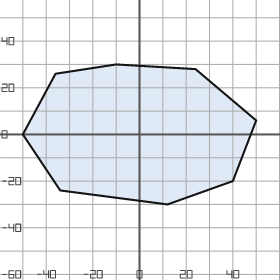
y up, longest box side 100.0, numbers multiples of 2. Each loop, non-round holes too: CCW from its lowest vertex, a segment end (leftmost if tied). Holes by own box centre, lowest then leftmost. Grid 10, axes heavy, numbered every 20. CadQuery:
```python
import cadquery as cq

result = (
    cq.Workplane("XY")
    .moveTo(12.0, -30.0)
    .lineTo(40.0, -20.0)
    .lineTo(50.0, 6.0)
    .lineTo(24.0, 28.0)
    .lineTo(-10.0, 30.0)
    .lineTo(-36.0, 26.0)
    .lineTo(-50.0, 0.0)
    .lineTo(-34.0, -24.0)
    .close()
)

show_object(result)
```